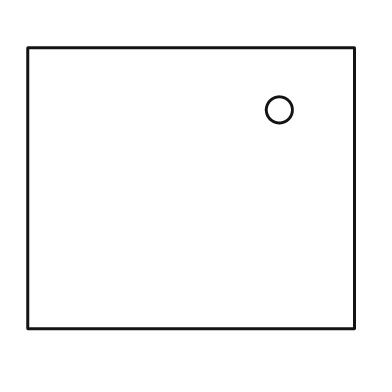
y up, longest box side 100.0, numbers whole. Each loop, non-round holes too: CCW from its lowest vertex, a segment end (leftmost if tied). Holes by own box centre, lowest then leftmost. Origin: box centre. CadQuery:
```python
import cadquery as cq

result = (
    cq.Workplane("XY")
    .moveTo(-50.0, -43.0)
    .lineTo(50.0, -43.0)
    .lineTo(50.0, 43.0)
    .lineTo(-50.0, 43.0)
    .close()
    .moveTo(27.0, 24.0)
    .circle(4.0)
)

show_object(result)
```